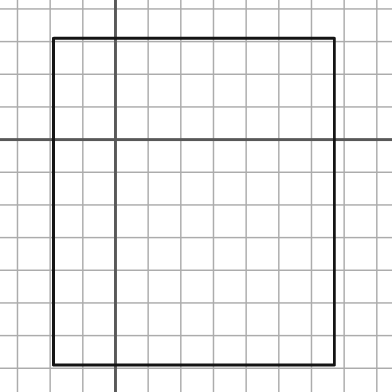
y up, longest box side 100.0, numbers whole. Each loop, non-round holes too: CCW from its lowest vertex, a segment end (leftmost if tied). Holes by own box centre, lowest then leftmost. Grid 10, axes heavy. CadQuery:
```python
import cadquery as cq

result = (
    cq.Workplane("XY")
    .moveTo(-19.0, -69.0)
    .lineTo(67.0, -69.0)
    .lineTo(67.0, 31.0)
    .lineTo(-19.0, 31.0)
    .close()
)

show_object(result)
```